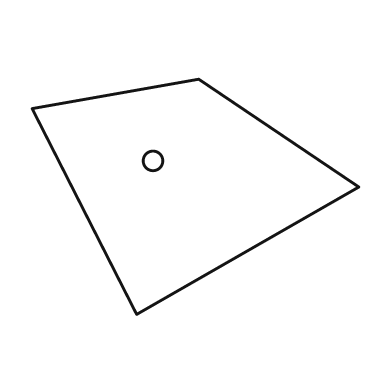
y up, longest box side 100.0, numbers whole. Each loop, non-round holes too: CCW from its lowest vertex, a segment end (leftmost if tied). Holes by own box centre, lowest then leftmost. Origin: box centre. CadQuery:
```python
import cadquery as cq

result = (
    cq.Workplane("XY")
    .moveTo(-18.0, -36.0)
    .lineTo(50.0, 3.0)
    .lineTo(1.0, 36.0)
    .lineTo(-50.0, 27.0)
    .close()
    .moveTo(-13.0, 11.0)
    .circle(3.0)
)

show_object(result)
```